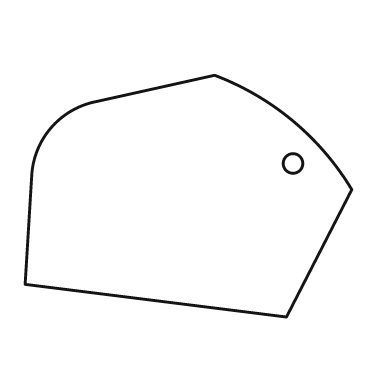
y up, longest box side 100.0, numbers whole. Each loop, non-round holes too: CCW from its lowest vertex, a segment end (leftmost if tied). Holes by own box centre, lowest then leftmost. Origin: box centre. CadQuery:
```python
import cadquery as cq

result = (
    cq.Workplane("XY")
    .moveTo(30.0, -37.0)
    .lineTo(50.0, 2.0)
    .threePointArc((32.0, 23.0), (8.0, 37.0))
    .lineTo(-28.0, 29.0)
    .threePointArc((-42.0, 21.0), (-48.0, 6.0))
    .lineTo(-50.0, -27.0)
    .close()
    .moveTo(32.0, 10.0)
    .circle(3.0)
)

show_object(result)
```